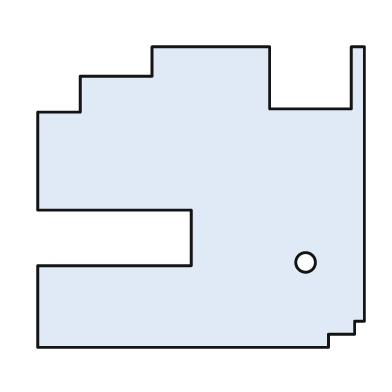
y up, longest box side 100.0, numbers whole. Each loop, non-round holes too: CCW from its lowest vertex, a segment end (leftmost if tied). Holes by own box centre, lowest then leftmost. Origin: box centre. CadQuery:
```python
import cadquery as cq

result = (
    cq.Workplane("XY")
    .moveTo(-50.0, -46.0)
    .lineTo(39.0, -46.0)
    .lineTo(39.0, -42.0)
    .lineTo(47.0, -42.0)
    .lineTo(47.0, -38.0)
    .lineTo(50.0, -38.0)
    .lineTo(50.0, 46.0)
    .lineTo(46.0, 46.0)
    .lineTo(46.0, 27.0)
    .lineTo(21.0, 27.0)
    .lineTo(21.0, 46.0)
    .lineTo(-15.0, 46.0)
    .lineTo(-15.0, 37.0)
    .lineTo(-37.0, 37.0)
    .lineTo(-37.0, 26.0)
    .lineTo(-50.0, 26.0)
    .lineTo(-50.0, -4.0)
    .lineTo(-3.0, -4.0)
    .lineTo(-3.0, -21.0)
    .lineTo(-50.0, -21.0)
    .close()
    .moveTo(32.0, -20.0)
    .circle(3.0)
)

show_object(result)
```